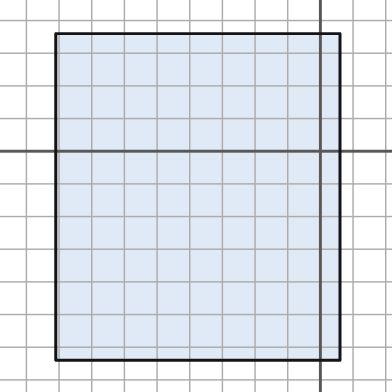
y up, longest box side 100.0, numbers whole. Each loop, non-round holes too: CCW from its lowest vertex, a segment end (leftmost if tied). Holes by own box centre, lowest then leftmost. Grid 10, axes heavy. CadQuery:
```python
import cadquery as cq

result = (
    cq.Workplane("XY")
    .moveTo(-81.0, -64.0)
    .lineTo(6.0, -64.0)
    .lineTo(6.0, 36.0)
    .lineTo(-81.0, 36.0)
    .close()
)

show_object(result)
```